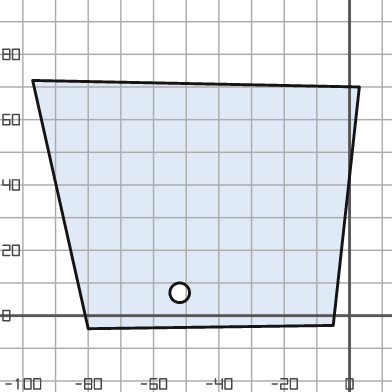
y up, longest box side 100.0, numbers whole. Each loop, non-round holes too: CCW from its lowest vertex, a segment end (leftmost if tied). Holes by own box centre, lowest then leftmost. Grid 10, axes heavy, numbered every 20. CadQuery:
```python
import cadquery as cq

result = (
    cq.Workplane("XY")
    .moveTo(-80.0, -4.0)
    .lineTo(-5.0, -3.0)
    .lineTo(3.0, 70.0)
    .lineTo(-97.0, 72.0)
    .close()
    .moveTo(-52.0, 7.0)
    .circle(3.0)
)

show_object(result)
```